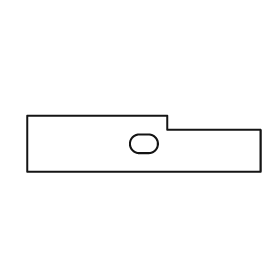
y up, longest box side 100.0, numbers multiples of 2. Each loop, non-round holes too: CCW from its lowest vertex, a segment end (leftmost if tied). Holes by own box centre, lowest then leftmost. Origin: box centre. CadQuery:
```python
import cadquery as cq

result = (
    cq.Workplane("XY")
    .moveTo(-50.0, -12.0)
    .lineTo(50.0, -12.0)
    .lineTo(50.0, 6.0)
    .lineTo(10.0, 6.0)
    .lineTo(10.0, 12.0)
    .lineTo(-50.0, 12.0)
    .close()
    .moveTo(-2.0, -4.0)
    .lineTo(2.0, -4.0)
    .threePointArc((6.0, 0.0), (2.0, 4.0))
    .lineTo(-2.0, 4.0)
    .threePointArc((-6.0, 0.0), (-2.0, -4.0))
    .close()
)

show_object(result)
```